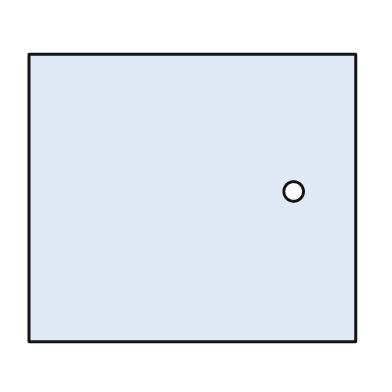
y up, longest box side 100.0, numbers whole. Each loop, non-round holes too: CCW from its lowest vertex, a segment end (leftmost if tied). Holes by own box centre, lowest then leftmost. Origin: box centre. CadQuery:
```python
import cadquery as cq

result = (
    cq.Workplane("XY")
    .moveTo(-50.0, -44.0)
    .lineTo(50.0, -44.0)
    .lineTo(50.0, 44.0)
    .lineTo(-50.0, 44.0)
    .close()
    .moveTo(31.0, 2.0)
    .circle(3.0)
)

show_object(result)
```